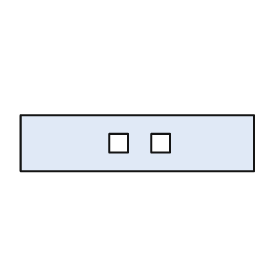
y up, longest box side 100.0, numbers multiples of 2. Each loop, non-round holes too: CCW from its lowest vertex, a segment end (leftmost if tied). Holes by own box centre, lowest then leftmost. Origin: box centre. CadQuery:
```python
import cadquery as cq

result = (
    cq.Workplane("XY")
    .moveTo(-50.0, -12.0)
    .lineTo(50.0, -12.0)
    .lineTo(50.0, 12.0)
    .lineTo(-50.0, 12.0)
    .close()
    .moveTo(-12.0, -4.0)
    .lineTo(-4.0, -4.0)
    .lineTo(-4.0, 4.0)
    .lineTo(-12.0, 4.0)
    .close()
    .moveTo(6.0, -4.0)
    .lineTo(14.0, -4.0)
    .lineTo(14.0, 4.0)
    .lineTo(6.0, 4.0)
    .close()
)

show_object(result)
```